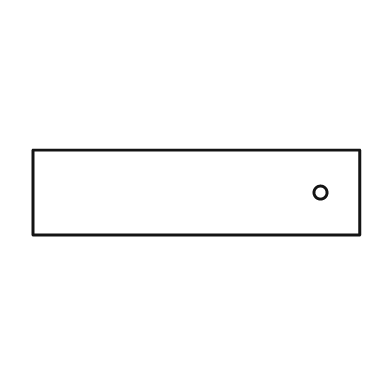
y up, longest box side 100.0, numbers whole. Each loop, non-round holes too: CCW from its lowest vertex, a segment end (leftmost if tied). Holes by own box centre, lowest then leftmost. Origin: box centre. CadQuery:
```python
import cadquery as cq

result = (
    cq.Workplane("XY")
    .moveTo(-50.0, -13.0)
    .lineTo(50.0, -13.0)
    .lineTo(50.0, 13.0)
    .lineTo(-50.0, 13.0)
    .close()
    .moveTo(38.0, 0.0)
    .circle(2.0)
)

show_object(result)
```